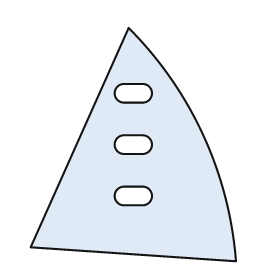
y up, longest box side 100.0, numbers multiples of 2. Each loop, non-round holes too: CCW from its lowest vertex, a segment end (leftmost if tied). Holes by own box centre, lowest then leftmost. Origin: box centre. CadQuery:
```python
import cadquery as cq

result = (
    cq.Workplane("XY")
    .moveTo(44.0, -50.0)
    .threePointArc((30.0, 4.0), (-2.0, 50.0))
    .lineTo(-44.0, -44.0)
    .close()
    .moveTo(-4.0, -26.0)
    .lineTo(4.0, -26.0)
    .threePointArc((8.0, -22.0), (4.0, -18.0))
    .lineTo(-4.0, -18.0)
    .threePointArc((-8.0, -22.0), (-4.0, -26.0))
    .close()
    .moveTo(-4.0, -4.0)
    .lineTo(4.0, -4.0)
    .threePointArc((8.0, 0.0), (4.0, 4.0))
    .lineTo(-4.0, 4.0)
    .threePointArc((-8.0, 0.0), (-4.0, -4.0))
    .close()
    .moveTo(-4.0, 18.0)
    .lineTo(4.0, 18.0)
    .threePointArc((8.0, 22.0), (4.0, 26.0))
    .lineTo(-4.0, 26.0)
    .threePointArc((-8.0, 22.0), (-4.0, 18.0))
    .close()
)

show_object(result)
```